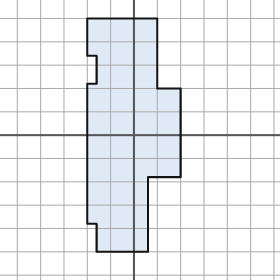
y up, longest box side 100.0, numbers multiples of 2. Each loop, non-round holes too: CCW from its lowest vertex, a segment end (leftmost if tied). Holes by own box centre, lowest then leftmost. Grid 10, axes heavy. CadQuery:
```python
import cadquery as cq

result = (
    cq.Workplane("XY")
    .moveTo(-16.0, -50.0)
    .lineTo(6.0, -50.0)
    .lineTo(6.0, -18.0)
    .lineTo(20.0, -18.0)
    .lineTo(20.0, 20.0)
    .lineTo(10.0, 20.0)
    .lineTo(10.0, 50.0)
    .lineTo(-20.0, 50.0)
    .lineTo(-20.0, 34.0)
    .lineTo(-16.0, 34.0)
    .lineTo(-16.0, 22.0)
    .lineTo(-20.0, 22.0)
    .lineTo(-20.0, -38.0)
    .lineTo(-16.0, -38.0)
    .close()
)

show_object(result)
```